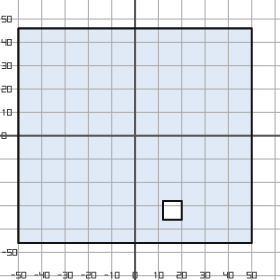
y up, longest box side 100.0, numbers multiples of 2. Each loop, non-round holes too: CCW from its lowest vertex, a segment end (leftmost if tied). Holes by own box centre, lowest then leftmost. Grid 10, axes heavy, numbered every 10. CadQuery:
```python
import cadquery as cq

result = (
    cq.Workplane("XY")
    .moveTo(-50.0, -46.0)
    .lineTo(50.0, -46.0)
    .lineTo(50.0, 46.0)
    .lineTo(-50.0, 46.0)
    .close()
    .moveTo(12.0, -36.0)
    .lineTo(20.0, -36.0)
    .lineTo(20.0, -28.0)
    .lineTo(12.0, -28.0)
    .close()
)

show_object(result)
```